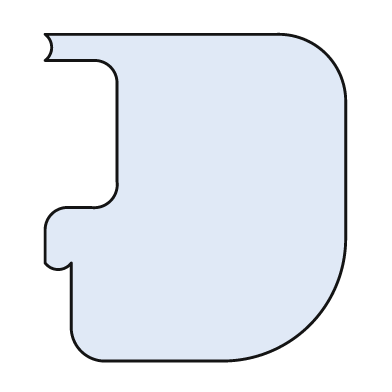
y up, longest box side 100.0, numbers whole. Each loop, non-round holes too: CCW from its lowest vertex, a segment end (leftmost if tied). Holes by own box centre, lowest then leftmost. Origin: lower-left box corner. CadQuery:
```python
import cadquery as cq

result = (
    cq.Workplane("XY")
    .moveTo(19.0, 0.0)
    .lineTo(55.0, 0.0)
    .threePointArc((81.0, 11.0), (92.0, 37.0))
    .lineTo(92.0, 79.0)
    .threePointArc((86.0, 94.0), (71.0, 100.0))
    .lineTo(0.0, 100.0)
    .threePointArc((2.0, 96.0), (0.0, 92.0))
    .lineTo(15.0, 92.0)
    .threePointArc((20.0, 90.0), (22.0, 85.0))
    .lineTo(22.0, 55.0)
    .threePointArc((20.0, 49.0), (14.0, 47.0))
    .lineTo(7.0, 47.0)
    .threePointArc((2.0, 45.0), (0.0, 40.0))
    .lineTo(0.0, 30.0)
    .threePointArc((4.0, 28.0), (8.0, 30.0))
    .lineTo(8.0, 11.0)
    .threePointArc((11.0, 3.0), (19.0, 0.0))
    .close()
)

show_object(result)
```